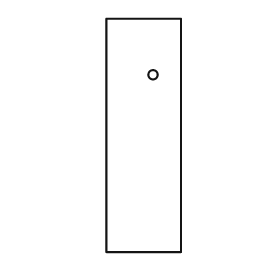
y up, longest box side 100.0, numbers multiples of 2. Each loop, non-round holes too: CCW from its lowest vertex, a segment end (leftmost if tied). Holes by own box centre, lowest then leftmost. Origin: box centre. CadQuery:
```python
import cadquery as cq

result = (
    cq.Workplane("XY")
    .moveTo(-16.0, -50.0)
    .lineTo(16.0, -50.0)
    .lineTo(16.0, 50.0)
    .lineTo(-16.0, 50.0)
    .close()
    .moveTo(4.0, 26.0)
    .circle(2.0)
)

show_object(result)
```